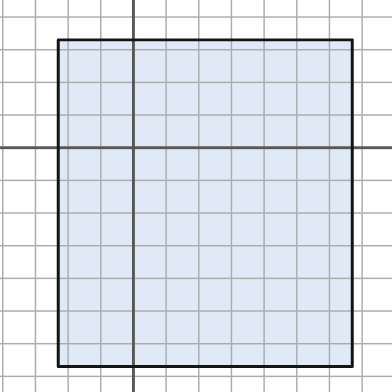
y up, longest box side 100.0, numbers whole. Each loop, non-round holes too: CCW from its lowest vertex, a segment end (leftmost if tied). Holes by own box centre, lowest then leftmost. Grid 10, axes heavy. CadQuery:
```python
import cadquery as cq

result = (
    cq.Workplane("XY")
    .moveTo(-23.0, -67.0)
    .lineTo(67.0, -67.0)
    .lineTo(67.0, 33.0)
    .lineTo(-23.0, 33.0)
    .close()
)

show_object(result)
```